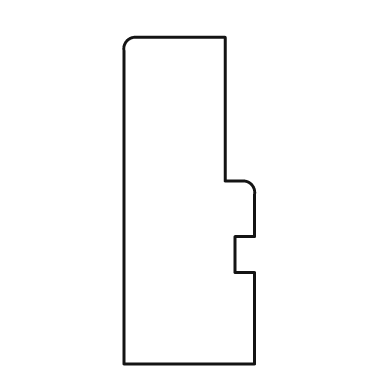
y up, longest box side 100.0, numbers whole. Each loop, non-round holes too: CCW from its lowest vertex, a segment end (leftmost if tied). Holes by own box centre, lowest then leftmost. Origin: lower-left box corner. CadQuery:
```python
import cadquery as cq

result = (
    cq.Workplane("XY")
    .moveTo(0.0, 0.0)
    .lineTo(40.0, 0.0)
    .lineTo(40.0, 28.0)
    .lineTo(34.0, 28.0)
    .lineTo(34.0, 39.0)
    .lineTo(40.0, 39.0)
    .lineTo(40.0, 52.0)
    .threePointArc((39.0, 55.0), (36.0, 56.0))
    .lineTo(31.0, 56.0)
    .lineTo(31.0, 100.0)
    .lineTo(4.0, 100.0)
    .threePointArc((1.0, 99.0), (0.0, 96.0))
    .close()
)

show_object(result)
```